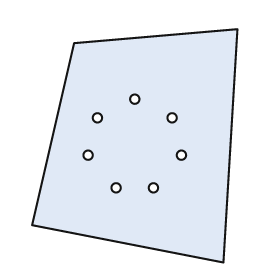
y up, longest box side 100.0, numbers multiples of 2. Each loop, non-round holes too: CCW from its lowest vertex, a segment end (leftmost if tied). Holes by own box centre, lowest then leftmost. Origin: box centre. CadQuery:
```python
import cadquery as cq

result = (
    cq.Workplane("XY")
    .moveTo(38.0, -50.0)
    .lineTo(44.0, 50.0)
    .lineTo(-26.0, 44.0)
    .lineTo(-44.0, -34.0)
    .close()
    .moveTo(-8.0, -18.0)
    .circle(2.0)
    .moveTo(8.0, -18.0)
    .circle(2.0)
    .moveTo(-20.0, -4.0)
    .circle(2.0)
    .moveTo(20.0, -4.0)
    .circle(2.0)
    .moveTo(-16.0, 12.0)
    .circle(2.0)
    .moveTo(16.0, 12.0)
    .circle(2.0)
    .moveTo(0.0, 20.0)
    .circle(2.0)
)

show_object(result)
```